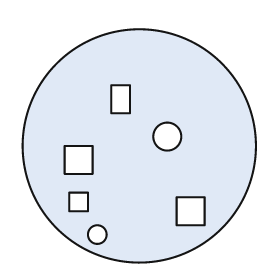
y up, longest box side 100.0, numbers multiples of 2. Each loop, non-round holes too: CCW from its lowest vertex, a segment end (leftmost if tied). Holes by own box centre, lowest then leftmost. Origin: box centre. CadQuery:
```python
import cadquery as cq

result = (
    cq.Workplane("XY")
    .moveTo(0.0, 0.0)
    .circle(50.0)
    .moveTo(-18.0, -38.0)
    .circle(4.0)
    .moveTo(16.0, -34.0)
    .lineTo(28.0, -34.0)
    .lineTo(28.0, -22.0)
    .lineTo(16.0, -22.0)
    .close()
    .moveTo(-30.0, -28.0)
    .lineTo(-22.0, -28.0)
    .lineTo(-22.0, -20.0)
    .lineTo(-30.0, -20.0)
    .close()
    .moveTo(-32.0, -12.0)
    .lineTo(-20.0, -12.0)
    .lineTo(-20.0, 0.0)
    .lineTo(-32.0, 0.0)
    .close()
    .moveTo(12.0, 4.0)
    .circle(6.0)
    .moveTo(-12.0, 14.0)
    .lineTo(-4.0, 14.0)
    .lineTo(-4.0, 26.0)
    .lineTo(-12.0, 26.0)
    .close()
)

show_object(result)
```